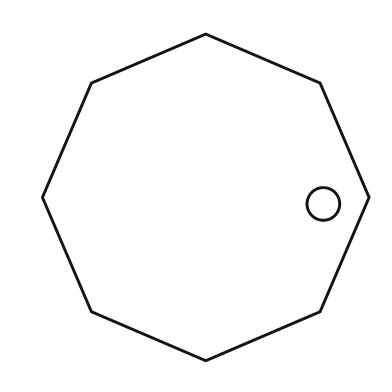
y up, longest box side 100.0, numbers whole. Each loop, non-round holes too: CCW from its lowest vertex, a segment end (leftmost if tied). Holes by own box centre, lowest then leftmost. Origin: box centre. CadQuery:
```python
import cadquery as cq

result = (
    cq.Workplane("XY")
    .moveTo(0.0, -50.0)
    .lineTo(35.0, -35.0)
    .lineTo(50.0, 0.0)
    .lineTo(35.0, 35.0)
    .lineTo(0.0, 50.0)
    .lineTo(-35.0, 35.0)
    .lineTo(-50.0, 0.0)
    .lineTo(-35.0, -35.0)
    .close()
    .moveTo(36.0, -2.0)
    .circle(5.0)
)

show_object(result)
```